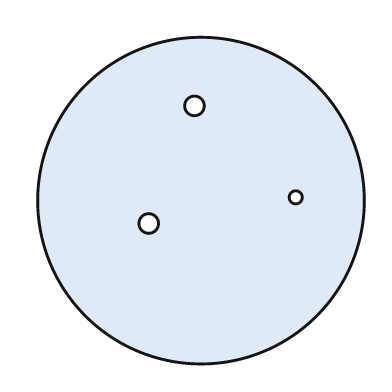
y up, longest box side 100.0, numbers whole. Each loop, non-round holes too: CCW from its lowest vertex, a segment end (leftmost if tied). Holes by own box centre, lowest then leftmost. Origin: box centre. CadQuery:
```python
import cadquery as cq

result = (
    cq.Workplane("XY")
    .moveTo(0.0, 0.0)
    .circle(50.0)
    .moveTo(-16.0, -7.0)
    .circle(3.0)
    .moveTo(29.0, 1.0)
    .circle(2.0)
    .moveTo(-2.0, 29.0)
    .circle(3.0)
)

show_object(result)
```